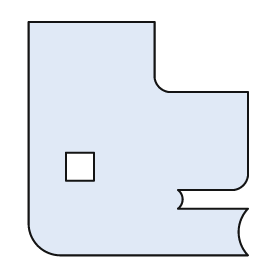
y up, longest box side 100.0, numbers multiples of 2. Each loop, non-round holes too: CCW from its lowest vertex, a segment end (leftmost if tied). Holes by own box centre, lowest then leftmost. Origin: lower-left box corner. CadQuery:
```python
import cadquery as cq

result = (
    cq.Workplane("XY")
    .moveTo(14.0, 0.0)
    .lineTo(94.0, 0.0)
    .threePointArc((90.0, 10.0), (94.0, 20.0))
    .lineTo(64.0, 20.0)
    .threePointArc((66.0, 24.0), (64.0, 28.0))
    .lineTo(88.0, 28.0)
    .threePointArc((92.0, 30.0), (94.0, 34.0))
    .lineTo(94.0, 70.0)
    .lineTo(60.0, 70.0)
    .threePointArc((56.0, 72.0), (54.0, 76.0))
    .lineTo(54.0, 100.0)
    .lineTo(0.0, 100.0)
    .lineTo(0.0, 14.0)
    .threePointArc((4.0, 4.0), (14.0, 0.0))
    .close()
    .moveTo(16.0, 32.0)
    .lineTo(28.0, 32.0)
    .lineTo(28.0, 44.0)
    .lineTo(16.0, 44.0)
    .close()
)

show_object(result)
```